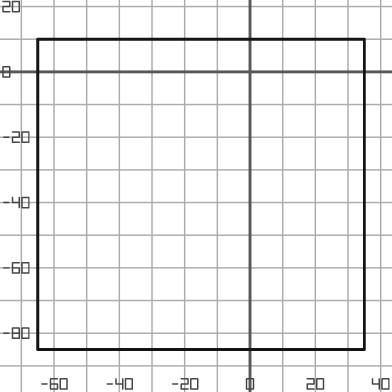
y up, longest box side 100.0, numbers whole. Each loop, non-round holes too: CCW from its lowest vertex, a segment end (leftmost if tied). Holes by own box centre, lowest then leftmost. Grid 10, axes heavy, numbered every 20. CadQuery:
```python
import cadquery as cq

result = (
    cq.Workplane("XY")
    .moveTo(-65.0, -85.0)
    .lineTo(35.0, -85.0)
    .lineTo(35.0, 10.0)
    .lineTo(-65.0, 10.0)
    .close()
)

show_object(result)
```